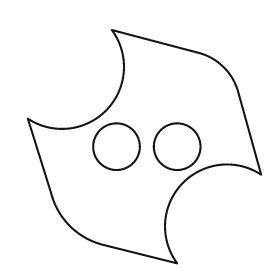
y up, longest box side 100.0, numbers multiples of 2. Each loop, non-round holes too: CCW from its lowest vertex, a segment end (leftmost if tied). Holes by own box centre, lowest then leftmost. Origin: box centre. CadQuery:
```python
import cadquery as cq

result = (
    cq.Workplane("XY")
    .moveTo(14.0, -50.0)
    .threePointArc((16.0, -16.0), (50.0, -12.0))
    .lineTo(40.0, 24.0)
    .threePointArc((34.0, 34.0), (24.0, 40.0))
    .lineTo(-14.0, 50.0)
    .threePointArc((-16.0, 16.0), (-50.0, 12.0))
    .lineTo(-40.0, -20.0)
    .threePointArc((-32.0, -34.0), (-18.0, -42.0))
    .close()
    .moveTo(-12.0, 0.0)
    .circle(10.0)
    .moveTo(14.0, 0.0)
    .circle(10.0)
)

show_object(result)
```